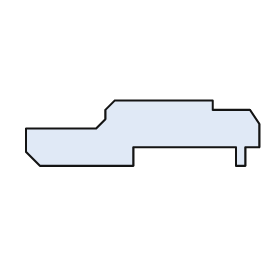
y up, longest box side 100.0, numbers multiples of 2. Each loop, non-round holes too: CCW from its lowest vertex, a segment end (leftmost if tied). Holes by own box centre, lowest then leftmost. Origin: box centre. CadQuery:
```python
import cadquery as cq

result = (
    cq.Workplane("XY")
    .moveTo(-44.0, -14.0)
    .lineTo(-4.0, -14.0)
    .lineTo(-4.0, -6.0)
    .lineTo(40.0, -6.0)
    .lineTo(40.0, -14.0)
    .lineTo(44.0, -14.0)
    .lineTo(44.0, -6.0)
    .lineTo(50.0, -6.0)
    .lineTo(50.0, 4.0)
    .lineTo(46.0, 10.0)
    .lineTo(30.0, 10.0)
    .lineTo(30.0, 14.0)
    .lineTo(-12.0, 14.0)
    .lineTo(-16.0, 10.0)
    .lineTo(-16.0, 6.0)
    .lineTo(-20.0, 2.0)
    .lineTo(-50.0, 2.0)
    .lineTo(-50.0, -8.0)
    .close()
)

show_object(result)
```